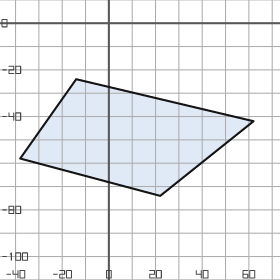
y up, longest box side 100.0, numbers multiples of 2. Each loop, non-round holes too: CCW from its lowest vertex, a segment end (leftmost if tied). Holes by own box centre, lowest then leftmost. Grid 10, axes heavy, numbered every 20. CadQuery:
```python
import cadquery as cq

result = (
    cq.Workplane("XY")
    .moveTo(22.0, -74.0)
    .lineTo(62.0, -42.0)
    .lineTo(-14.0, -24.0)
    .lineTo(-38.0, -58.0)
    .close()
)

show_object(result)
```